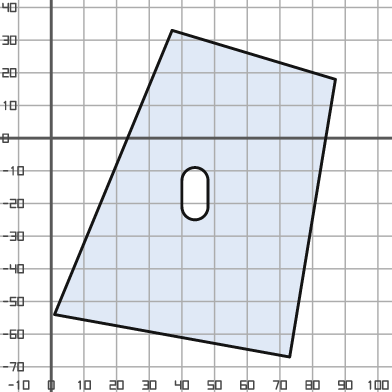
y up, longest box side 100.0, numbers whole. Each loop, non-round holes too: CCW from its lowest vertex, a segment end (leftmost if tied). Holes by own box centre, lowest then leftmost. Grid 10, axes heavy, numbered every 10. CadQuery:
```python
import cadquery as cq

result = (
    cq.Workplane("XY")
    .moveTo(73.0, -67.0)
    .lineTo(87.0, 18.0)
    .lineTo(37.0, 33.0)
    .lineTo(1.0, -54.0)
    .close()
    .moveTo(40.0, -21.0)
    .threePointArc((44.0, -25.0), (48.0, -21.0))
    .lineTo(48.0, -13.0)
    .threePointArc((44.0, -9.0), (40.0, -13.0))
    .close()
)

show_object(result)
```